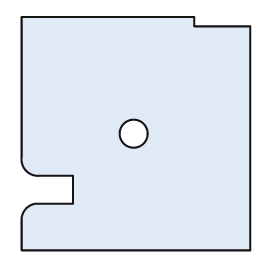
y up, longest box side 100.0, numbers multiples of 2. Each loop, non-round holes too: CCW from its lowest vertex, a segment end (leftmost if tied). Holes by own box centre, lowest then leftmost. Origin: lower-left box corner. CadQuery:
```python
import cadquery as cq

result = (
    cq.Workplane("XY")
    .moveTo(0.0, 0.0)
    .lineTo(98.0, 0.0)
    .lineTo(98.0, 96.0)
    .lineTo(74.0, 96.0)
    .lineTo(74.0, 100.0)
    .lineTo(0.0, 100.0)
    .lineTo(0.0, 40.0)
    .threePointArc((2.0, 34.0), (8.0, 32.0))
    .lineTo(22.0, 32.0)
    .lineTo(22.0, 20.0)
    .lineTo(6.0, 20.0)
    .threePointArc((2.0, 18.0), (0.0, 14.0))
    .close()
    .moveTo(48.0, 50.0)
    .circle(6.0)
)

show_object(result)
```